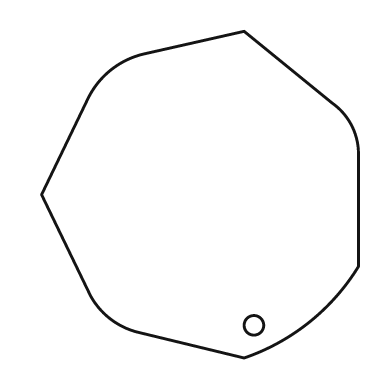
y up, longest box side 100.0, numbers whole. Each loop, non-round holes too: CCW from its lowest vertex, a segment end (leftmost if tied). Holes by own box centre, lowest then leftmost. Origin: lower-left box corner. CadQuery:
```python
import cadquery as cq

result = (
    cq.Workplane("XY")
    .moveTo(62.0, 0.0)
    .threePointArc((82.0, 11.0), (97.0, 28.0))
    .lineTo(97.0, 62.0)
    .threePointArc((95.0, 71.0), (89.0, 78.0))
    .lineTo(62.0, 100.0)
    .lineTo(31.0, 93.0)
    .threePointArc((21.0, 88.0), (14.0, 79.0))
    .lineTo(0.0, 50.0)
    .lineTo(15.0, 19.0)
    .threePointArc((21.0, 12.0), (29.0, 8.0))
    .close()
    .moveTo(65.0, 10.0)
    .circle(3.0)
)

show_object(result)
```